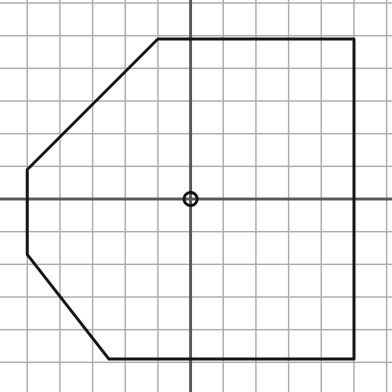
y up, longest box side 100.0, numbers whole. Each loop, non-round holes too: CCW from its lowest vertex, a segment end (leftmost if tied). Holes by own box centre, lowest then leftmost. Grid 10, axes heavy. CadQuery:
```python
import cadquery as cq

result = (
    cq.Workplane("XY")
    .moveTo(-25.0, -49.0)
    .lineTo(50.0, -49.0)
    .lineTo(50.0, 49.0)
    .lineTo(-10.0, 49.0)
    .lineTo(-50.0, 9.0)
    .lineTo(-50.0, -17.0)
    .close()
    .moveTo(0.0, 0.0)
    .circle(2.0)
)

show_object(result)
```